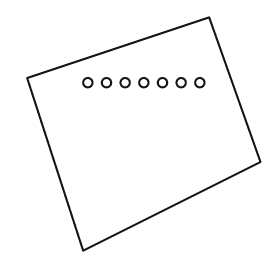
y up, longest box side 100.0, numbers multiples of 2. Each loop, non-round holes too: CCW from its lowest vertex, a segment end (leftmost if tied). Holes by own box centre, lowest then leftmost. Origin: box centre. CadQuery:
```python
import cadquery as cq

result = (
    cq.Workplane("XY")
    .moveTo(-26.0, -50.0)
    .lineTo(50.0, -12.0)
    .lineTo(28.0, 50.0)
    .lineTo(-50.0, 24.0)
    .close()
    .moveTo(-24.0, 22.0)
    .circle(2.0)
    .moveTo(-16.0, 22.0)
    .circle(2.0)
    .moveTo(-8.0, 22.0)
    .circle(2.0)
    .moveTo(0.0, 22.0)
    .circle(2.0)
    .moveTo(8.0, 22.0)
    .circle(2.0)
    .moveTo(16.0, 22.0)
    .circle(2.0)
    .moveTo(24.0, 22.0)
    .circle(2.0)
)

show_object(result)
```